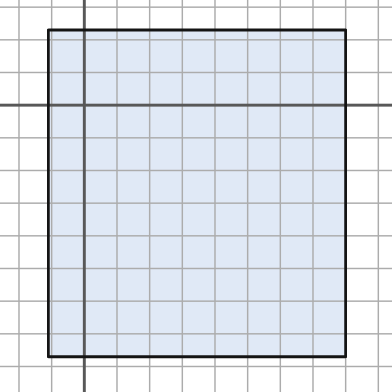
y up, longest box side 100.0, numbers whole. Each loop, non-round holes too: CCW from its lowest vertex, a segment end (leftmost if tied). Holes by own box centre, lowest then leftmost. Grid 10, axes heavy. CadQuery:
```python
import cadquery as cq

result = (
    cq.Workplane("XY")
    .moveTo(-11.0, -77.0)
    .lineTo(80.0, -77.0)
    .lineTo(80.0, 23.0)
    .lineTo(-11.0, 23.0)
    .close()
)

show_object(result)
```